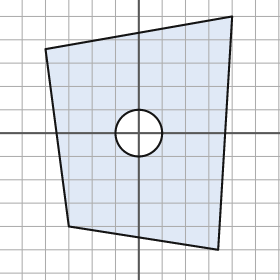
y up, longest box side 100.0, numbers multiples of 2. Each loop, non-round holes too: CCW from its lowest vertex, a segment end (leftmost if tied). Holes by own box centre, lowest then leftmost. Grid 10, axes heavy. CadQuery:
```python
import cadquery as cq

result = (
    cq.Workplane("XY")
    .moveTo(34.0, -50.0)
    .lineTo(40.0, 50.0)
    .lineTo(-40.0, 36.0)
    .lineTo(-30.0, -40.0)
    .close()
    .moveTo(0.0, 0.0)
    .circle(10.0)
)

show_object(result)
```